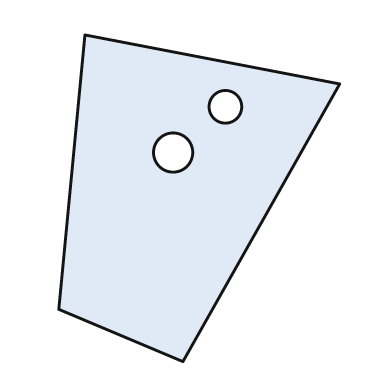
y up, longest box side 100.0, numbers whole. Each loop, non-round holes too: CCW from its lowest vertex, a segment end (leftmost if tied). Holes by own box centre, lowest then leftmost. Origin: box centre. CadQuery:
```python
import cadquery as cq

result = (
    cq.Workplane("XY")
    .moveTo(-5.0, -50.0)
    .lineTo(43.0, 35.0)
    .lineTo(-35.0, 50.0)
    .lineTo(-43.0, -34.0)
    .close()
    .moveTo(-8.0, 14.0)
    .circle(6.0)
    .moveTo(8.0, 28.0)
    .circle(5.0)
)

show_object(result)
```